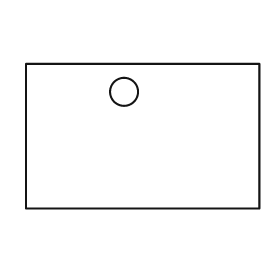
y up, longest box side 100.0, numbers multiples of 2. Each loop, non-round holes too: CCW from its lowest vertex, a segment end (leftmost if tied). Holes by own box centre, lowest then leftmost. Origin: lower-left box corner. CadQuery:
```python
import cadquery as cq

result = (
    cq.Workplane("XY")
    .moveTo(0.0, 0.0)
    .lineTo(100.0, 0.0)
    .lineTo(100.0, 62.0)
    .lineTo(0.0, 62.0)
    .close()
    .moveTo(42.0, 50.0)
    .circle(6.0)
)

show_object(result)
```